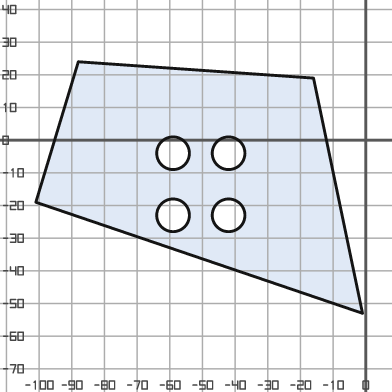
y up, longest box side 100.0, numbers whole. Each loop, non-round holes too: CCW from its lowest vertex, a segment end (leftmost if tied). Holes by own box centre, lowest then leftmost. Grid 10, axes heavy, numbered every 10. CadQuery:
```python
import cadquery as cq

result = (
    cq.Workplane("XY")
    .moveTo(-1.0, -53.0)
    .lineTo(-16.0, 19.0)
    .lineTo(-88.0, 24.0)
    .lineTo(-101.0, -19.0)
    .close()
    .moveTo(-59.0, -23.0)
    .circle(5.0)
    .moveTo(-42.0, -23.0)
    .circle(5.0)
    .moveTo(-59.0, -4.0)
    .circle(5.0)
    .moveTo(-42.0, -4.0)
    .circle(5.0)
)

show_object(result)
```